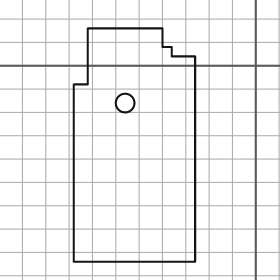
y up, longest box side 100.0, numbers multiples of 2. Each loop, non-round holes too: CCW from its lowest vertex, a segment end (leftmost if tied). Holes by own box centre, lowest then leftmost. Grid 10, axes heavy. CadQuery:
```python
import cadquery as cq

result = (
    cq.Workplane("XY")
    .moveTo(-78.0, -84.0)
    .lineTo(-26.0, -84.0)
    .lineTo(-26.0, 4.0)
    .lineTo(-36.0, 4.0)
    .lineTo(-36.0, 8.0)
    .lineTo(-40.0, 8.0)
    .lineTo(-40.0, 16.0)
    .lineTo(-72.0, 16.0)
    .lineTo(-72.0, -8.0)
    .lineTo(-78.0, -8.0)
    .close()
    .moveTo(-56.0, -16.0)
    .circle(4.0)
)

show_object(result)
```